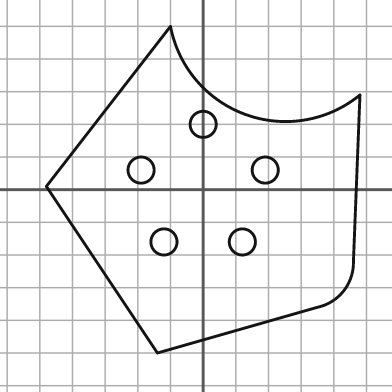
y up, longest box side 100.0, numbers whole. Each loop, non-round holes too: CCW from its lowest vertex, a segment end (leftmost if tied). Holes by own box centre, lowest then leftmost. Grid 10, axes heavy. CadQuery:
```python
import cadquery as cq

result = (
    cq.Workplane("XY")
    .moveTo(-14.0, -50.0)
    .lineTo(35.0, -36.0)
    .threePointArc((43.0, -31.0), (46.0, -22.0))
    .lineTo(48.0, 29.0)
    .threePointArc((13.0, 23.0), (-10.0, 50.0))
    .lineTo(-48.0, 1.0)
    .close()
    .moveTo(-12.0, -16.0)
    .circle(4.0)
    .moveTo(12.0, -16.0)
    .circle(4.0)
    .moveTo(-19.0, 6.0)
    .circle(4.0)
    .moveTo(19.0, 6.0)
    .circle(4.0)
    .moveTo(0.0, 20.0)
    .circle(4.0)
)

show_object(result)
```